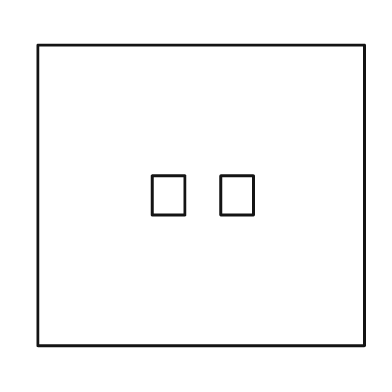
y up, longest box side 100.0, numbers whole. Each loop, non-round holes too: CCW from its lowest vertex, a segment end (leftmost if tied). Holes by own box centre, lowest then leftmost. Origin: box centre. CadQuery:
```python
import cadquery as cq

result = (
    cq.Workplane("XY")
    .moveTo(-50.0, -46.0)
    .lineTo(50.0, -46.0)
    .lineTo(50.0, 46.0)
    .lineTo(-50.0, 46.0)
    .close()
    .moveTo(-15.0, -6.0)
    .lineTo(-5.0, -6.0)
    .lineTo(-5.0, 6.0)
    .lineTo(-15.0, 6.0)
    .close()
    .moveTo(6.0, -6.0)
    .lineTo(16.0, -6.0)
    .lineTo(16.0, 6.0)
    .lineTo(6.0, 6.0)
    .close()
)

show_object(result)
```